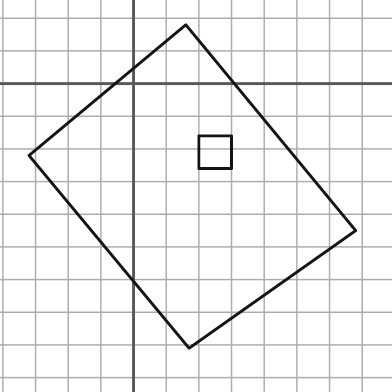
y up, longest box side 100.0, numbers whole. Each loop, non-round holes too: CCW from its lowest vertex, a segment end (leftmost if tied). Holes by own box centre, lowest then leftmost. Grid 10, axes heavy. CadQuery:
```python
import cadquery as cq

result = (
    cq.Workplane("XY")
    .moveTo(17.0, -81.0)
    .lineTo(68.0, -45.0)
    .lineTo(16.0, 18.0)
    .lineTo(-32.0, -22.0)
    .close()
    .moveTo(20.0, -26.0)
    .lineTo(30.0, -26.0)
    .lineTo(30.0, -16.0)
    .lineTo(20.0, -16.0)
    .close()
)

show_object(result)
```